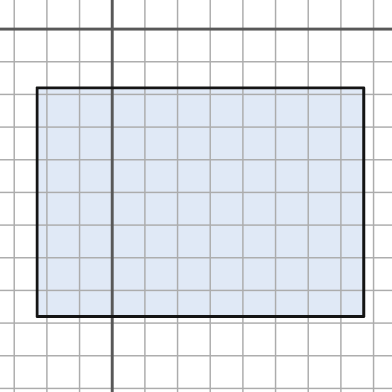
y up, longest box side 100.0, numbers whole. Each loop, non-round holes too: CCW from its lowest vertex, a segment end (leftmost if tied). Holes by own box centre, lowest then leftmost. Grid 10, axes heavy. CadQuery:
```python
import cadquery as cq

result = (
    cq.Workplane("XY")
    .moveTo(-23.0, -88.0)
    .lineTo(77.0, -88.0)
    .lineTo(77.0, -18.0)
    .lineTo(-23.0, -18.0)
    .close()
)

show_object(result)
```